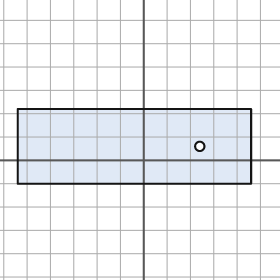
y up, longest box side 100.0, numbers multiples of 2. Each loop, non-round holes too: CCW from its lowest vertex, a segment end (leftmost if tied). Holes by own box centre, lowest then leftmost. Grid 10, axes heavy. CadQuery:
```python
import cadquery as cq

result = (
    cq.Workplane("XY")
    .moveTo(-54.0, -10.0)
    .lineTo(46.0, -10.0)
    .lineTo(46.0, 22.0)
    .lineTo(-54.0, 22.0)
    .close()
    .moveTo(24.0, 6.0)
    .circle(2.0)
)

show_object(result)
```